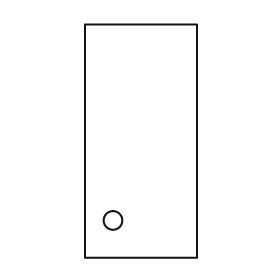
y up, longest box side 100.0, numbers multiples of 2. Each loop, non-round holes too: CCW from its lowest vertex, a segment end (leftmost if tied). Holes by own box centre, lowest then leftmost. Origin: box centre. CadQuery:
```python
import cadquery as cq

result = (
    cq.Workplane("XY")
    .moveTo(-24.0, -50.0)
    .lineTo(24.0, -50.0)
    .lineTo(24.0, 50.0)
    .lineTo(-24.0, 50.0)
    .close()
    .moveTo(-12.0, -34.0)
    .circle(4.0)
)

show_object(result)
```